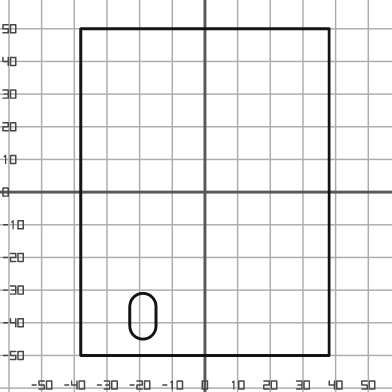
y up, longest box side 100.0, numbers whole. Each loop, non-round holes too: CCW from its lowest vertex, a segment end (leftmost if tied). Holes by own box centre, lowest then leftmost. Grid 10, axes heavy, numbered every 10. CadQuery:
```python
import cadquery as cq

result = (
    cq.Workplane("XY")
    .moveTo(-38.0, -50.0)
    .lineTo(38.0, -50.0)
    .lineTo(38.0, 50.0)
    .lineTo(-38.0, 50.0)
    .close()
    .moveTo(-23.0, -41.0)
    .threePointArc((-19.0, -45.0), (-15.0, -41.0))
    .lineTo(-15.0, -35.0)
    .threePointArc((-19.0, -31.0), (-23.0, -35.0))
    .close()
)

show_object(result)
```